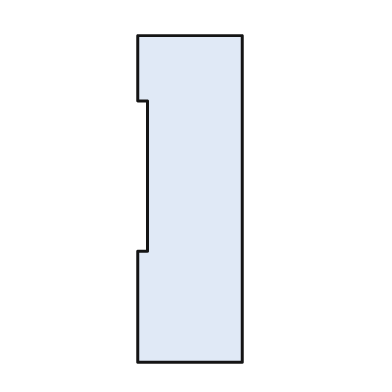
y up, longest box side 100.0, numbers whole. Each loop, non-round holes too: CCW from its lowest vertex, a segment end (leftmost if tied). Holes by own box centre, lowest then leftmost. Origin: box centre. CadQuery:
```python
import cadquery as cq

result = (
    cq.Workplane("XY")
    .moveTo(-16.0, -50.0)
    .lineTo(16.0, -50.0)
    .lineTo(16.0, 50.0)
    .lineTo(-16.0, 50.0)
    .lineTo(-16.0, 30.0)
    .lineTo(-13.0, 30.0)
    .lineTo(-13.0, -16.0)
    .lineTo(-16.0, -16.0)
    .close()
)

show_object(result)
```